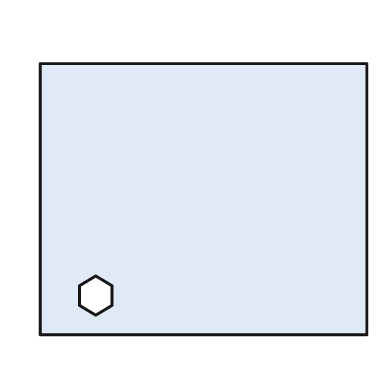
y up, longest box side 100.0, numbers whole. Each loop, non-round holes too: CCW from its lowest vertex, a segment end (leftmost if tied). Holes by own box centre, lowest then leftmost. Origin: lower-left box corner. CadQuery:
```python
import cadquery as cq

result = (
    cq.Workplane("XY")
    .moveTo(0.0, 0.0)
    .lineTo(100.0, 0.0)
    .lineTo(100.0, 83.0)
    .lineTo(0.0, 83.0)
    .close()
    .moveTo(17.0, 6.0)
    .lineTo(22.0, 9.0)
    .lineTo(22.0, 15.0)
    .lineTo(17.0, 18.0)
    .lineTo(12.0, 15.0)
    .lineTo(12.0, 9.0)
    .close()
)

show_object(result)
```